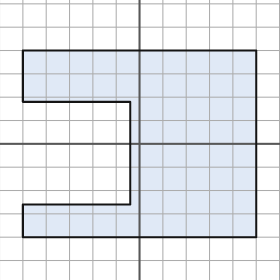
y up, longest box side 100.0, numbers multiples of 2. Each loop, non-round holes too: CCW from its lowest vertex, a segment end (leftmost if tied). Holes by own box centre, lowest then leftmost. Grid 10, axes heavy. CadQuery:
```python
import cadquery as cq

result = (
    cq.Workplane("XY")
    .moveTo(-50.0, -40.0)
    .lineTo(50.0, -40.0)
    .lineTo(50.0, 40.0)
    .lineTo(-50.0, 40.0)
    .lineTo(-50.0, 18.0)
    .lineTo(-4.0, 18.0)
    .lineTo(-4.0, -26.0)
    .lineTo(-50.0, -26.0)
    .close()
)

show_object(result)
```